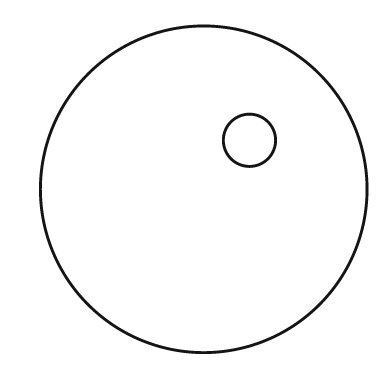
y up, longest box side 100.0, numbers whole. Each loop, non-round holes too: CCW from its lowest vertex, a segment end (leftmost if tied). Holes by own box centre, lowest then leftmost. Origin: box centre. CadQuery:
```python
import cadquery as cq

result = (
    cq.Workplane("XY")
    .moveTo(0.0, 0.0)
    .circle(50.0)
    .moveTo(14.0, 15.0)
    .circle(8.0)
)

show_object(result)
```